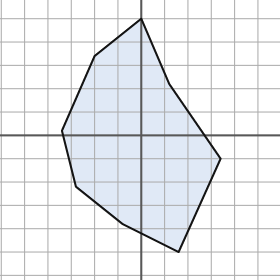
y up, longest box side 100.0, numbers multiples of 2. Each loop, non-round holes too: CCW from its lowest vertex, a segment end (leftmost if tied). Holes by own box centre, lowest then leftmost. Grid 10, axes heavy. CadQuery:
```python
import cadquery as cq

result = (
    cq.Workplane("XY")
    .moveTo(16.0, -50.0)
    .lineTo(34.0, -10.0)
    .lineTo(12.0, 22.0)
    .lineTo(0.0, 50.0)
    .lineTo(-20.0, 34.0)
    .lineTo(-34.0, 2.0)
    .lineTo(-28.0, -22.0)
    .lineTo(-8.0, -38.0)
    .close()
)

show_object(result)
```